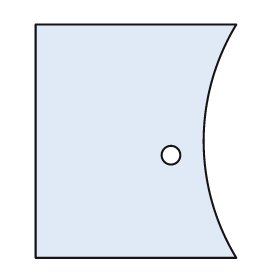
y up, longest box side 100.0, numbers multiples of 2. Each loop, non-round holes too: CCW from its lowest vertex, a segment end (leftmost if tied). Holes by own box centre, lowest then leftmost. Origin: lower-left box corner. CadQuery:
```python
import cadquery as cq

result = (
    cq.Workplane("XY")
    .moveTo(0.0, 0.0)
    .lineTo(86.0, 0.0)
    .threePointArc((72.0, 50.0), (86.0, 100.0))
    .lineTo(0.0, 100.0)
    .close()
    .moveTo(58.0, 44.0)
    .circle(4.0)
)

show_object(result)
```